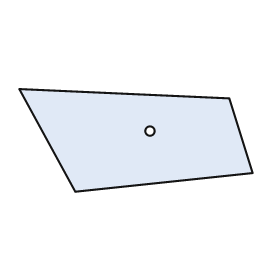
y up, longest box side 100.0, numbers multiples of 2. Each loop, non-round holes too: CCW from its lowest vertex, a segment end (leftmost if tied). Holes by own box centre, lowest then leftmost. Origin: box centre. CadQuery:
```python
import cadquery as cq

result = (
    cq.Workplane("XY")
    .moveTo(-26.0, -22.0)
    .lineTo(50.0, -14.0)
    .lineTo(40.0, 18.0)
    .lineTo(-50.0, 22.0)
    .close()
    .moveTo(6.0, 4.0)
    .circle(2.0)
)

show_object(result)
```